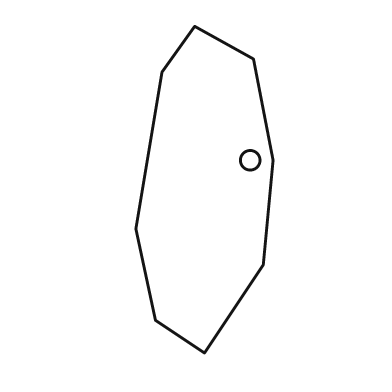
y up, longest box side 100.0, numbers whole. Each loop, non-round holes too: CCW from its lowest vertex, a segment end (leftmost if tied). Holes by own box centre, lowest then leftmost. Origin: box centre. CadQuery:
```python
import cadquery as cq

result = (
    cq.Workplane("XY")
    .moveTo(0.0, -50.0)
    .lineTo(18.0, -23.0)
    .lineTo(21.0, 9.0)
    .lineTo(15.0, 40.0)
    .lineTo(-3.0, 50.0)
    .lineTo(-13.0, 36.0)
    .lineTo(-21.0, -12.0)
    .lineTo(-15.0, -40.0)
    .close()
    .moveTo(14.0, 9.0)
    .circle(3.0)
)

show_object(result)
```